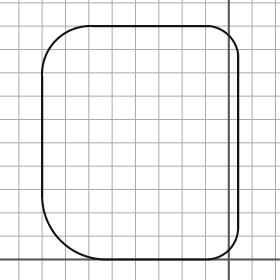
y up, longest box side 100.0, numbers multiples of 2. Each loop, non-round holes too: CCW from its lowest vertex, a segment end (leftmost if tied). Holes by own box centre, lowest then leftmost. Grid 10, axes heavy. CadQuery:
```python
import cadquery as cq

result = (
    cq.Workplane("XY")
    .moveTo(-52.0, 0.0)
    .lineTo(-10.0, 0.0)
    .threePointArc((0.0, 4.0), (4.0, 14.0))
    .lineTo(4.0, 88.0)
    .threePointArc((0.0, 96.0), (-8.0, 100.0))
    .lineTo(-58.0, 100.0)
    .threePointArc((-74.0, 94.0), (-80.0, 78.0))
    .lineTo(-80.0, 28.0)
    .threePointArc((-72.0, 8.0), (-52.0, 0.0))
    .close()
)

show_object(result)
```